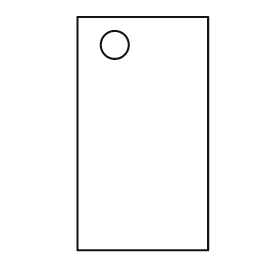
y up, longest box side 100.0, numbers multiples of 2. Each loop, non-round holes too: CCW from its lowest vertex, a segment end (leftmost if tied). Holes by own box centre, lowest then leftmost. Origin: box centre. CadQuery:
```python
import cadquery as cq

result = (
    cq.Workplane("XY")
    .moveTo(-28.0, -50.0)
    .lineTo(28.0, -50.0)
    .lineTo(28.0, 50.0)
    .lineTo(-28.0, 50.0)
    .close()
    .moveTo(-12.0, 38.0)
    .circle(6.0)
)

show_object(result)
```